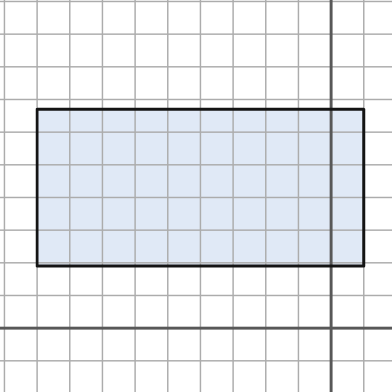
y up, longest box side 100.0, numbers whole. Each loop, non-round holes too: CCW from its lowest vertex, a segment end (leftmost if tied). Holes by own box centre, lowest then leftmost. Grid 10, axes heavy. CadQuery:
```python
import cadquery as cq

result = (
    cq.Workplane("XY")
    .moveTo(-90.0, 19.0)
    .lineTo(10.0, 19.0)
    .lineTo(10.0, 67.0)
    .lineTo(-90.0, 67.0)
    .close()
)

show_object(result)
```